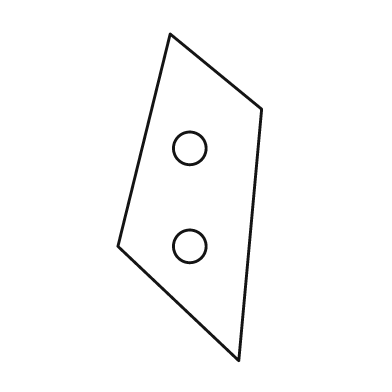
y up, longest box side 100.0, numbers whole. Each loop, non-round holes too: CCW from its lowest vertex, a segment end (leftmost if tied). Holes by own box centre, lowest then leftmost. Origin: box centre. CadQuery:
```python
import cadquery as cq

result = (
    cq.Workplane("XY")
    .moveTo(15.0, -50.0)
    .lineTo(22.0, 27.0)
    .lineTo(-6.0, 50.0)
    .lineTo(-22.0, -15.0)
    .close()
    .moveTo(0.0, -15.0)
    .circle(5.0)
    .moveTo(0.0, 15.0)
    .circle(5.0)
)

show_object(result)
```